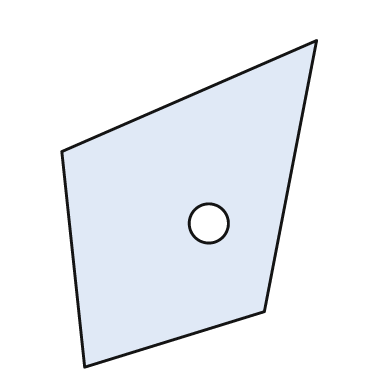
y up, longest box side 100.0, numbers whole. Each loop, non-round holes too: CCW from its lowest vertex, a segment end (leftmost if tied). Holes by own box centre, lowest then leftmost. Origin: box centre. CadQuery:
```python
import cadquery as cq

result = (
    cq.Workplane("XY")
    .moveTo(-32.0, -50.0)
    .lineTo(23.0, -33.0)
    .lineTo(39.0, 50.0)
    .lineTo(-39.0, 16.0)
    .close()
    .moveTo(6.0, -6.0)
    .circle(6.0)
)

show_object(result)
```